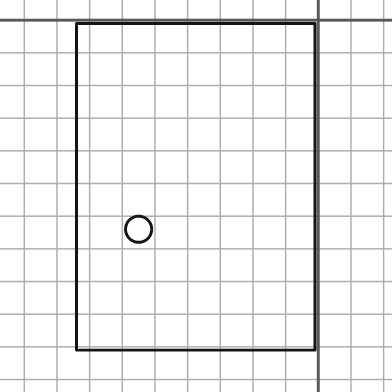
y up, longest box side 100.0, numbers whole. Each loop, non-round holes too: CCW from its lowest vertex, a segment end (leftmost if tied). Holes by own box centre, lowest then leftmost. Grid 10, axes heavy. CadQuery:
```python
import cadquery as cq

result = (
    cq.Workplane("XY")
    .moveTo(-74.0, -101.0)
    .lineTo(-1.0, -101.0)
    .lineTo(-1.0, -1.0)
    .lineTo(-74.0, -1.0)
    .close()
    .moveTo(-55.0, -64.0)
    .circle(4.0)
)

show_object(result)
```